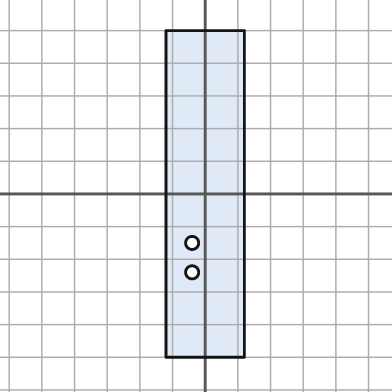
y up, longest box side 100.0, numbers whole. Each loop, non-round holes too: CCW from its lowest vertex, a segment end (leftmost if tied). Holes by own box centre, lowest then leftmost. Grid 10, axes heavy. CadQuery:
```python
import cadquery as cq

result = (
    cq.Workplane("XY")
    .moveTo(-12.0, -50.0)
    .lineTo(12.0, -50.0)
    .lineTo(12.0, 50.0)
    .lineTo(-12.0, 50.0)
    .close()
    .moveTo(-4.0, -24.0)
    .circle(2.0)
    .moveTo(-4.0, -15.0)
    .circle(2.0)
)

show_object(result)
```